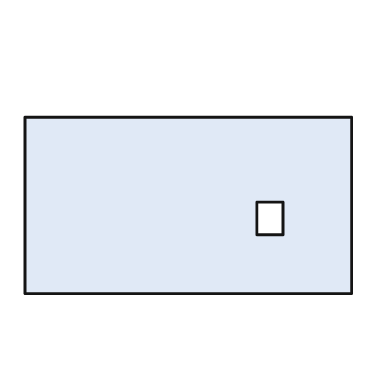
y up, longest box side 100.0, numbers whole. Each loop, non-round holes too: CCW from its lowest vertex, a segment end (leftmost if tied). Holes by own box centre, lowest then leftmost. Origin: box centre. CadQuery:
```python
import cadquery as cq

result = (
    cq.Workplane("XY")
    .moveTo(-50.0, -27.0)
    .lineTo(50.0, -27.0)
    .lineTo(50.0, 27.0)
    .lineTo(-50.0, 27.0)
    .close()
    .moveTo(21.0, -9.0)
    .lineTo(29.0, -9.0)
    .lineTo(29.0, 1.0)
    .lineTo(21.0, 1.0)
    .close()
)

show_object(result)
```